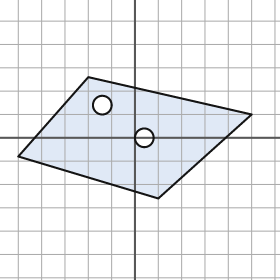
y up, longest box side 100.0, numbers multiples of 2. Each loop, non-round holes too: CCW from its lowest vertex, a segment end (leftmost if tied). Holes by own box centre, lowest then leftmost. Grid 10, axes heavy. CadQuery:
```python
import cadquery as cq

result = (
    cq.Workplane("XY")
    .moveTo(10.0, -26.0)
    .lineTo(50.0, 10.0)
    .lineTo(-20.0, 26.0)
    .lineTo(-50.0, -8.0)
    .close()
    .moveTo(4.0, 0.0)
    .circle(4.0)
    .moveTo(-14.0, 14.0)
    .circle(4.0)
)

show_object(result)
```